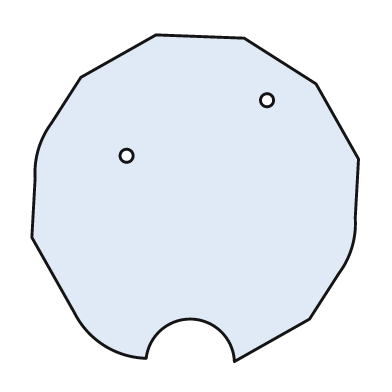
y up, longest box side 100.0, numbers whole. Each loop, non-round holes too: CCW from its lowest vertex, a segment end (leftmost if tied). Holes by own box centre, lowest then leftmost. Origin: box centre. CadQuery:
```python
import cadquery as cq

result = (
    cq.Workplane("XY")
    .moveTo(12.0, -50.0)
    .lineTo(35.0, -37.0)
    .lineTo(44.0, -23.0)
    .threePointArc((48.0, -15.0), (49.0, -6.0))
    .lineTo(50.0, 12.0)
    .lineTo(37.0, 35.0)
    .lineTo(15.0, 49.0)
    .lineTo(-12.0, 50.0)
    .lineTo(-35.0, 37.0)
    .lineTo(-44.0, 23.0)
    .threePointArc((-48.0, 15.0), (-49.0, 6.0))
    .lineTo(-50.0, -12.0)
    .lineTo(-37.0, -35.0)
    .threePointArc((-28.0, -45.0), (-15.0, -49.0))
    .threePointArc((-1.0, -37.0), (12.0, -50.0))
    .close()
    .moveTo(-21.0, 13.0)
    .circle(2.0)
    .moveTo(22.0, 30.0)
    .circle(2.0)
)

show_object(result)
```